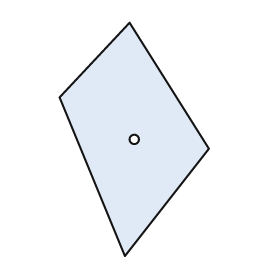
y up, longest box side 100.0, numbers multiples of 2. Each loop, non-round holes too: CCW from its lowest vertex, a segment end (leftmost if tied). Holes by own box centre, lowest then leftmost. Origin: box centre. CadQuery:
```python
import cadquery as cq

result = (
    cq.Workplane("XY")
    .moveTo(-4.0, -50.0)
    .lineTo(32.0, -4.0)
    .lineTo(-2.0, 50.0)
    .lineTo(-32.0, 18.0)
    .close()
    .moveTo(0.0, 0.0)
    .circle(2.0)
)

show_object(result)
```